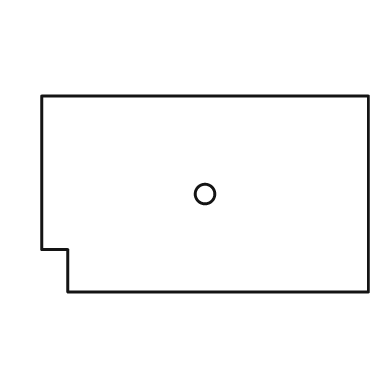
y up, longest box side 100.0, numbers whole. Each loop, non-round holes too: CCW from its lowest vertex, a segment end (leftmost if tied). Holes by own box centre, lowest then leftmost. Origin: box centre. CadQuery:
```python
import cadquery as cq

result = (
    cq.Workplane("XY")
    .moveTo(-42.0, -30.0)
    .lineTo(50.0, -30.0)
    .lineTo(50.0, 30.0)
    .lineTo(-50.0, 30.0)
    .lineTo(-50.0, -17.0)
    .lineTo(-42.0, -17.0)
    .close()
    .moveTo(0.0, 0.0)
    .circle(3.0)
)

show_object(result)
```